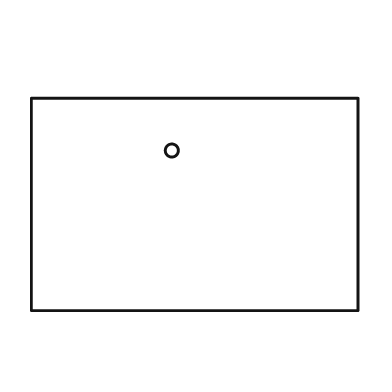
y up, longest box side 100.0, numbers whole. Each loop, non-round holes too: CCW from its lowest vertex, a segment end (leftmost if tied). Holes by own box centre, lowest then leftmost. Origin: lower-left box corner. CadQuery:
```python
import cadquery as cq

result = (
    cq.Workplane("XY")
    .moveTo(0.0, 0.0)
    .lineTo(100.0, 0.0)
    .lineTo(100.0, 65.0)
    .lineTo(0.0, 65.0)
    .close()
    .moveTo(43.0, 49.0)
    .circle(2.0)
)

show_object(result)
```